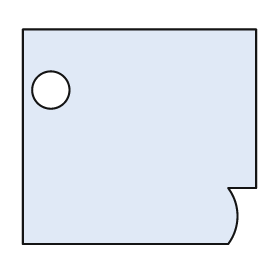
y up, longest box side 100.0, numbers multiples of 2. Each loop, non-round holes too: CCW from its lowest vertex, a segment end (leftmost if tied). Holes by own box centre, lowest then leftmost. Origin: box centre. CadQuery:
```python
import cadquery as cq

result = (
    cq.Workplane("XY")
    .moveTo(-50.0, -46.0)
    .lineTo(38.0, -46.0)
    .threePointArc((42.0, -34.0), (38.0, -22.0))
    .lineTo(50.0, -22.0)
    .lineTo(50.0, 46.0)
    .lineTo(-50.0, 46.0)
    .close()
    .moveTo(-38.0, 20.0)
    .circle(8.0)
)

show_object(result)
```